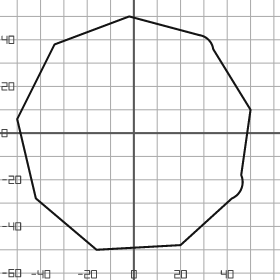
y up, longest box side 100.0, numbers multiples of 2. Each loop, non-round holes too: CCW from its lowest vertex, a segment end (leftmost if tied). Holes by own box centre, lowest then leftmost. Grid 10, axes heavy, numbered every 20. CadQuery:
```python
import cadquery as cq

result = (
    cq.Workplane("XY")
    .moveTo(-16.0, -50.0)
    .lineTo(20.0, -48.0)
    .lineTo(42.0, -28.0)
    .threePointArc((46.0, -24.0), (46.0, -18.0))
    .lineTo(50.0, 10.0)
    .lineTo(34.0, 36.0)
    .threePointArc((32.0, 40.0), (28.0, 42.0))
    .lineTo(-2.0, 50.0)
    .lineTo(-34.0, 38.0)
    .lineTo(-50.0, 6.0)
    .lineTo(-42.0, -28.0)
    .close()
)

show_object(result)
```